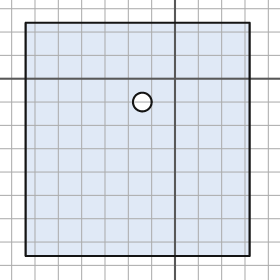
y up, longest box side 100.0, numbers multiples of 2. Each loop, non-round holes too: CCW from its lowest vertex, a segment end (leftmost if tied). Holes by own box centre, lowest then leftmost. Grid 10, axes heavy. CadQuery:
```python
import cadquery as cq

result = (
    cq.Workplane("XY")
    .moveTo(-64.0, -76.0)
    .lineTo(32.0, -76.0)
    .lineTo(32.0, 24.0)
    .lineTo(-64.0, 24.0)
    .close()
    .moveTo(-14.0, -10.0)
    .circle(4.0)
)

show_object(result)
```